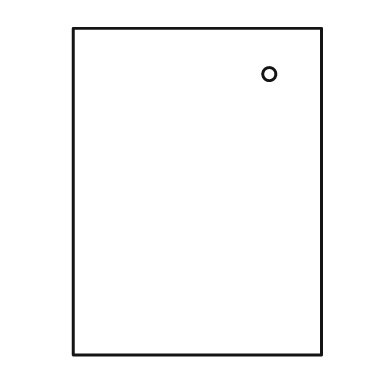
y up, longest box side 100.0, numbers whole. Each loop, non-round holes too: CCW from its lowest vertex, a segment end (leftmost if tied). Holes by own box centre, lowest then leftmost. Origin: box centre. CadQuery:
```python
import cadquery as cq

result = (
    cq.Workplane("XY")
    .moveTo(-38.0, -50.0)
    .lineTo(38.0, -50.0)
    .lineTo(38.0, 50.0)
    .lineTo(-38.0, 50.0)
    .close()
    .moveTo(22.0, 36.0)
    .circle(2.0)
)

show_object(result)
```